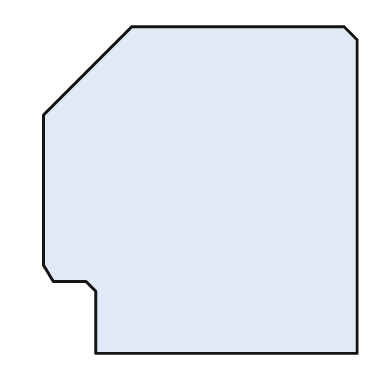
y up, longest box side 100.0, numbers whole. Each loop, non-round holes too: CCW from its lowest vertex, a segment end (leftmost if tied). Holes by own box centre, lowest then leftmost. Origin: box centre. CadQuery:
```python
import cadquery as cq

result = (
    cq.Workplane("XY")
    .moveTo(-32.0, -50.0)
    .lineTo(48.0, -50.0)
    .lineTo(48.0, 46.0)
    .lineTo(44.0, 50.0)
    .lineTo(-21.0, 50.0)
    .lineTo(-48.0, 23.0)
    .lineTo(-48.0, -23.0)
    .lineTo(-45.0, -28.0)
    .lineTo(-35.0, -28.0)
    .lineTo(-32.0, -31.0)
    .close()
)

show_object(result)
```